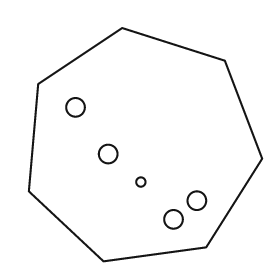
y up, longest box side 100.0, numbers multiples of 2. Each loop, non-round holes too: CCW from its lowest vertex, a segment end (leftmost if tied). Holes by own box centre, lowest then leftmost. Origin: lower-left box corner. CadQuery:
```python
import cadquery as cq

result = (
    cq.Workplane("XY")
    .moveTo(32.0, 0.0)
    .lineTo(76.0, 6.0)
    .lineTo(100.0, 44.0)
    .lineTo(84.0, 86.0)
    .lineTo(40.0, 100.0)
    .lineTo(4.0, 76.0)
    .lineTo(0.0, 30.0)
    .close()
    .moveTo(62.0, 18.0)
    .circle(4.0)
    .moveTo(72.0, 26.0)
    .circle(4.0)
    .moveTo(48.0, 34.0)
    .circle(2.0)
    .moveTo(34.0, 46.0)
    .circle(4.0)
    .moveTo(20.0, 66.0)
    .circle(4.0)
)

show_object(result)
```